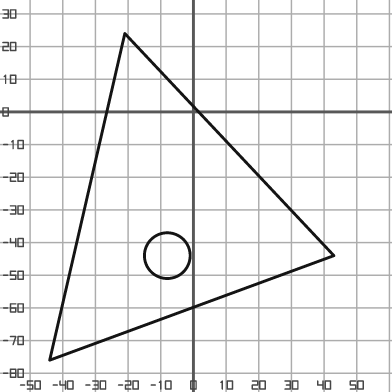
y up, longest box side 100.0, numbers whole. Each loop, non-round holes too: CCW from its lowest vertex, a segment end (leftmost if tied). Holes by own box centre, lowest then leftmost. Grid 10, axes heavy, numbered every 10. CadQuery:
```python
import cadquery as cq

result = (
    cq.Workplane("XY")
    .moveTo(-44.0, -76.0)
    .lineTo(43.0, -44.0)
    .lineTo(-21.0, 24.0)
    .close()
    .moveTo(-8.0, -44.0)
    .circle(7.0)
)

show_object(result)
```